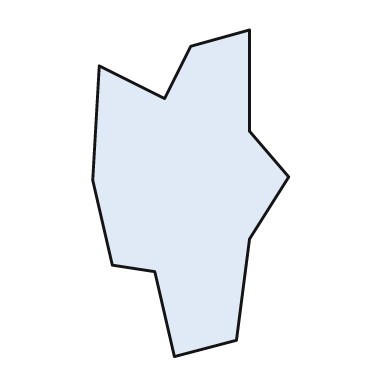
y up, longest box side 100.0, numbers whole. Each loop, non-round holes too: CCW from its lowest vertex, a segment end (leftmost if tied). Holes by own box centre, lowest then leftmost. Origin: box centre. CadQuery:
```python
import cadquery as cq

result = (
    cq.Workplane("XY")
    .moveTo(-5.0, -50.0)
    .lineTo(14.0, -45.0)
    .lineTo(18.0, -14.0)
    .lineTo(30.0, 5.0)
    .lineTo(18.0, 19.0)
    .lineTo(18.0, 50.0)
    .lineTo(0.0, 45.0)
    .lineTo(-8.0, 29.0)
    .lineTo(-28.0, 39.0)
    .lineTo(-30.0, 4.0)
    .lineTo(-24.0, -22.0)
    .lineTo(-11.0, -24.0)
    .close()
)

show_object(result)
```